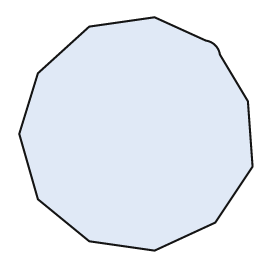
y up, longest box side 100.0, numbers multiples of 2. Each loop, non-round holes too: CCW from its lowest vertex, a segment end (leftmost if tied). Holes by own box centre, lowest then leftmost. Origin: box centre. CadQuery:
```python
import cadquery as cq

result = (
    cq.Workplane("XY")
    .moveTo(8.0, -50.0)
    .lineTo(34.0, -38.0)
    .lineTo(50.0, -14.0)
    .lineTo(48.0, 14.0)
    .lineTo(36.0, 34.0)
    .threePointArc((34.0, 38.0), (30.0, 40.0))
    .lineTo(8.0, 50.0)
    .lineTo(-20.0, 46.0)
    .lineTo(-42.0, 26.0)
    .lineTo(-50.0, 0.0)
    .lineTo(-42.0, -28.0)
    .lineTo(-20.0, -46.0)
    .close()
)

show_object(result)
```